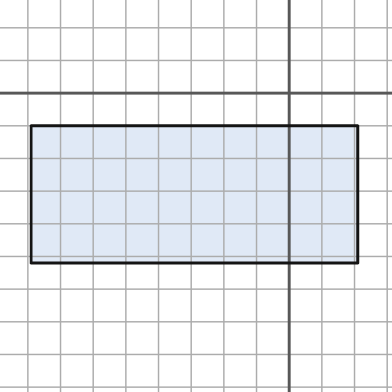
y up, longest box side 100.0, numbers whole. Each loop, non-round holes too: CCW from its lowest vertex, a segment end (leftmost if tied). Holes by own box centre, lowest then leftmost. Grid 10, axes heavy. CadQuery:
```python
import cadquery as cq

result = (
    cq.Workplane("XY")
    .moveTo(-79.0, -52.0)
    .lineTo(21.0, -52.0)
    .lineTo(21.0, -10.0)
    .lineTo(-79.0, -10.0)
    .close()
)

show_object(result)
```